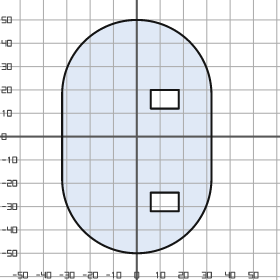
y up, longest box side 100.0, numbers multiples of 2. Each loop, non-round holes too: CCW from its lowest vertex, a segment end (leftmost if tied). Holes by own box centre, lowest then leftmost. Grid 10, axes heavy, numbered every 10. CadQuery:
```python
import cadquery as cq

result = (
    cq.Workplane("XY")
    .moveTo(-32.0, -18.0)
    .threePointArc((0.0, -50.0), (32.0, -18.0))
    .lineTo(32.0, 18.0)
    .threePointArc((0.0, 50.0), (-32.0, 18.0))
    .close()
    .moveTo(6.0, -32.0)
    .lineTo(18.0, -32.0)
    .lineTo(18.0, -24.0)
    .lineTo(6.0, -24.0)
    .close()
    .moveTo(6.0, 12.0)
    .lineTo(18.0, 12.0)
    .lineTo(18.0, 20.0)
    .lineTo(6.0, 20.0)
    .close()
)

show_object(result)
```